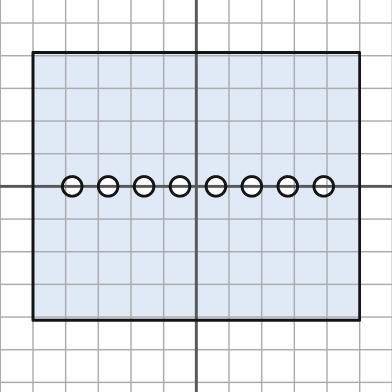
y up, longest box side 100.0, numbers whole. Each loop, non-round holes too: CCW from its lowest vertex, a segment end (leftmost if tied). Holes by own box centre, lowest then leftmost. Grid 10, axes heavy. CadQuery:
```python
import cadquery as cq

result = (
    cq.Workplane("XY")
    .moveTo(-50.0, -41.0)
    .lineTo(50.0, -41.0)
    .lineTo(50.0, 41.0)
    .lineTo(-50.0, 41.0)
    .close()
    .moveTo(-38.0, 0.0)
    .circle(3.0)
    .moveTo(-27.0, 0.0)
    .circle(3.0)
    .moveTo(-16.0, 0.0)
    .circle(3.0)
    .moveTo(-5.0, 0.0)
    .circle(3.0)
    .moveTo(6.0, 0.0)
    .circle(3.0)
    .moveTo(17.0, 0.0)
    .circle(3.0)
    .moveTo(28.0, 0.0)
    .circle(3.0)
    .moveTo(39.0, 0.0)
    .circle(3.0)
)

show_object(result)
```